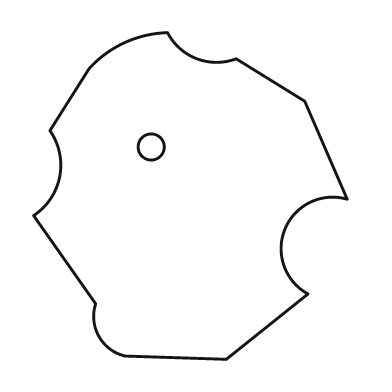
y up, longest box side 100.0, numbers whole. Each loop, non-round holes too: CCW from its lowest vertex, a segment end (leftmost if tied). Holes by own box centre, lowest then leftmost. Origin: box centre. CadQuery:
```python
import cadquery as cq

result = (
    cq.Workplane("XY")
    .moveTo(11.0, -50.0)
    .lineTo(36.0, -30.0)
    .threePointArc((29.0, -10.0), (48.0, -1.0))
    .lineTo(35.0, 29.0)
    .lineTo(14.0, 42.0)
    .threePointArc((2.0, 42.0), (-7.0, 50.0))
    .threePointArc((-20.0, 47.0), (-31.0, 39.0))
    .lineTo(-43.0, 20.0)
    .threePointArc((-40.0, 6.0), (-48.0, -6.0))
    .lineTo(-29.0, -33.0)
    .threePointArc((-28.0, -43.0), (-20.0, -49.0))
    .close()
    .moveTo(-12.0, 15.0)
    .circle(4.0)
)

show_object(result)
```